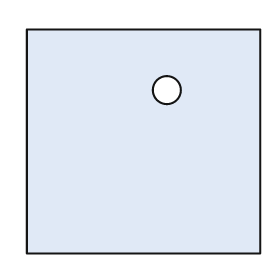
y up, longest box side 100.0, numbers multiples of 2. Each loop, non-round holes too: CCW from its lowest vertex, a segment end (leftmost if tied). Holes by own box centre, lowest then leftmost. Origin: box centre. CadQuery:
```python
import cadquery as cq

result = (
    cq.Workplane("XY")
    .moveTo(-50.0, -48.0)
    .lineTo(50.0, -48.0)
    .lineTo(50.0, 48.0)
    .lineTo(-50.0, 48.0)
    .close()
    .moveTo(10.0, 22.0)
    .circle(6.0)
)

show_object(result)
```